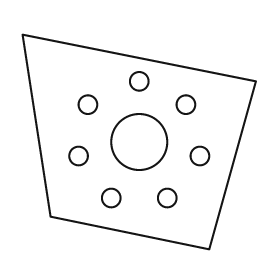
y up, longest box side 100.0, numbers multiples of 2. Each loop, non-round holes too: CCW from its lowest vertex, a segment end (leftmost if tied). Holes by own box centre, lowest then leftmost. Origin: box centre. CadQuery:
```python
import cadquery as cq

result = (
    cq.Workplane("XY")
    .moveTo(30.0, -46.0)
    .lineTo(50.0, 26.0)
    .lineTo(-50.0, 46.0)
    .lineTo(-38.0, -32.0)
    .close()
    .moveTo(-12.0, -24.0)
    .circle(4.0)
    .moveTo(12.0, -24.0)
    .circle(4.0)
    .moveTo(-26.0, -6.0)
    .circle(4.0)
    .moveTo(26.0, -6.0)
    .circle(4.0)
    .moveTo(0.0, 0.0)
    .circle(12.0)
    .moveTo(-22.0, 16.0)
    .circle(4.0)
    .moveTo(20.0, 16.0)
    .circle(4.0)
    .moveTo(0.0, 26.0)
    .circle(4.0)
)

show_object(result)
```